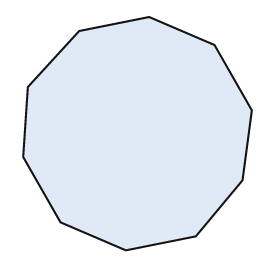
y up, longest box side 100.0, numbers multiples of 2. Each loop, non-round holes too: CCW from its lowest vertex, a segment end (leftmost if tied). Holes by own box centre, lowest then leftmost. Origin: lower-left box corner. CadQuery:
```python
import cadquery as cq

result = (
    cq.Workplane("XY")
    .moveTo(44.0, 0.0)
    .lineTo(74.0, 6.0)
    .lineTo(94.0, 30.0)
    .lineTo(98.0, 60.0)
    .lineTo(82.0, 88.0)
    .lineTo(54.0, 100.0)
    .lineTo(24.0, 94.0)
    .lineTo(2.0, 70.0)
    .lineTo(0.0, 40.0)
    .lineTo(16.0, 12.0)
    .close()
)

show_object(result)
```